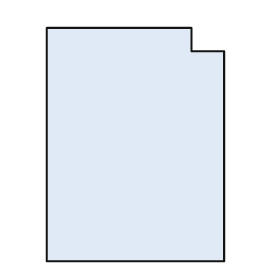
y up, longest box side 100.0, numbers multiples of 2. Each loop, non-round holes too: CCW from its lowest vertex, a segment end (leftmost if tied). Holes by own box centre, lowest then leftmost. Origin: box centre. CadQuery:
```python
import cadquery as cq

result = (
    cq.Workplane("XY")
    .moveTo(-38.0, -50.0)
    .lineTo(38.0, -50.0)
    .lineTo(38.0, 40.0)
    .lineTo(24.0, 40.0)
    .lineTo(24.0, 50.0)
    .lineTo(-38.0, 50.0)
    .close()
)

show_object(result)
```